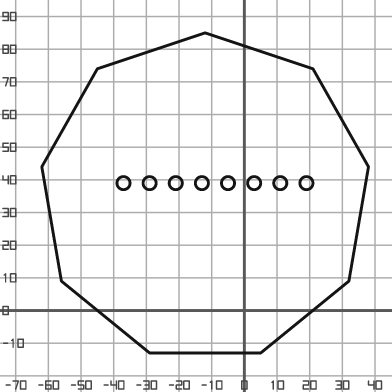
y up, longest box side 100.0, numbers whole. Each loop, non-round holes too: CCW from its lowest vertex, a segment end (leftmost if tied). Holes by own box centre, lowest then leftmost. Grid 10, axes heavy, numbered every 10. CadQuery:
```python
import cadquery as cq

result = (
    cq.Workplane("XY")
    .moveTo(-29.0, -13.0)
    .lineTo(5.0, -13.0)
    .lineTo(32.0, 9.0)
    .lineTo(38.0, 44.0)
    .lineTo(21.0, 74.0)
    .lineTo(-12.0, 85.0)
    .lineTo(-45.0, 74.0)
    .lineTo(-62.0, 44.0)
    .lineTo(-56.0, 9.0)
    .close()
    .moveTo(-37.0, 39.0)
    .circle(2.0)
    .moveTo(-29.0, 39.0)
    .circle(2.0)
    .moveTo(-21.0, 39.0)
    .circle(2.0)
    .moveTo(-13.0, 39.0)
    .circle(2.0)
    .moveTo(-5.0, 39.0)
    .circle(2.0)
    .moveTo(3.0, 39.0)
    .circle(2.0)
    .moveTo(11.0, 39.0)
    .circle(2.0)
    .moveTo(19.0, 39.0)
    .circle(2.0)
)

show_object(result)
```